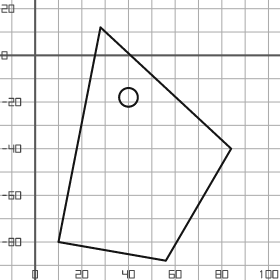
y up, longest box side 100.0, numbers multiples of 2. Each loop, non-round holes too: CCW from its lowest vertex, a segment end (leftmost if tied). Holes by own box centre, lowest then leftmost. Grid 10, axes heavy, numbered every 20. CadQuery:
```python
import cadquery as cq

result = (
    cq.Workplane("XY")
    .moveTo(56.0, -88.0)
    .lineTo(84.0, -40.0)
    .lineTo(28.0, 12.0)
    .lineTo(10.0, -80.0)
    .close()
    .moveTo(40.0, -18.0)
    .circle(4.0)
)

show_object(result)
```